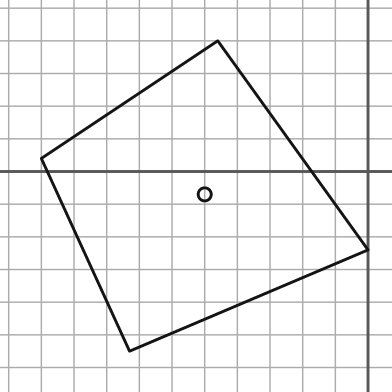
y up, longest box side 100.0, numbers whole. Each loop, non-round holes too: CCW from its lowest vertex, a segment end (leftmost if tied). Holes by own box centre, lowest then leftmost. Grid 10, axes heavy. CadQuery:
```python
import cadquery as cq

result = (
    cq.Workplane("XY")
    .moveTo(-73.0, -55.0)
    .lineTo(0.0, -24.0)
    .lineTo(-46.0, 40.0)
    .lineTo(-100.0, 4.0)
    .close()
    .moveTo(-50.0, -7.0)
    .circle(2.0)
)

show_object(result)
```